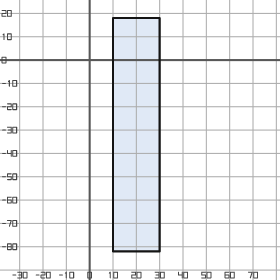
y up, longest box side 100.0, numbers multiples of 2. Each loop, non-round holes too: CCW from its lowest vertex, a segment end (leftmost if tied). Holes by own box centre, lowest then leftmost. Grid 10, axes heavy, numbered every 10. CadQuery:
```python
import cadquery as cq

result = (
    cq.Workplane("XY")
    .moveTo(10.0, -82.0)
    .lineTo(30.0, -82.0)
    .lineTo(30.0, 18.0)
    .lineTo(10.0, 18.0)
    .close()
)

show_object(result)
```